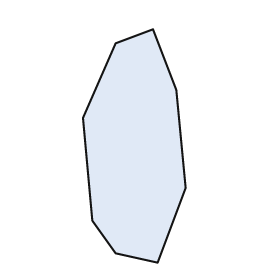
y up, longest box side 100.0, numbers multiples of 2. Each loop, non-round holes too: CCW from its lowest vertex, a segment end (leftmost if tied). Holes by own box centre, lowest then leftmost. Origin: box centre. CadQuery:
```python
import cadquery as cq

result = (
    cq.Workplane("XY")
    .moveTo(10.0, -50.0)
    .lineTo(22.0, -18.0)
    .lineTo(18.0, 24.0)
    .lineTo(8.0, 50.0)
    .lineTo(-8.0, 44.0)
    .lineTo(-22.0, 12.0)
    .lineTo(-18.0, -32.0)
    .lineTo(-8.0, -46.0)
    .close()
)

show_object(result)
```